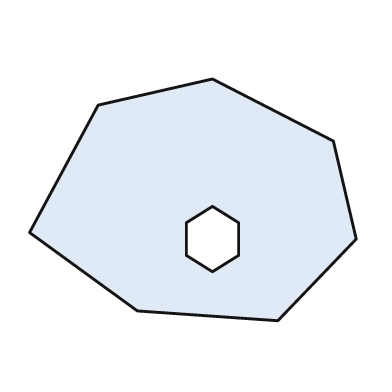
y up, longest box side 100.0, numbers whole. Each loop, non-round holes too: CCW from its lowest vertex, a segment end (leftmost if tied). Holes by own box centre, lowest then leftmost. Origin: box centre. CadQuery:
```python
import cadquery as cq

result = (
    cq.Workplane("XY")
    .moveTo(26.0, -37.0)
    .lineTo(50.0, -12.0)
    .lineTo(43.0, 18.0)
    .lineTo(6.0, 37.0)
    .lineTo(-29.0, 29.0)
    .lineTo(-50.0, -10.0)
    .lineTo(-17.0, -34.0)
    .close()
    .moveTo(6.0, -22.0)
    .lineTo(14.0, -17.0)
    .lineTo(14.0, -7.0)
    .lineTo(6.0, -2.0)
    .lineTo(-2.0, -7.0)
    .lineTo(-2.0, -17.0)
    .close()
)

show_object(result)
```